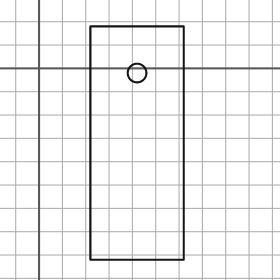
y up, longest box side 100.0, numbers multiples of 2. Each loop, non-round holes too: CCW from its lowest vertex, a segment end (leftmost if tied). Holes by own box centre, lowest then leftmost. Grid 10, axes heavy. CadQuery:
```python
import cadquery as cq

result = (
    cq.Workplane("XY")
    .moveTo(22.0, -82.0)
    .lineTo(62.0, -82.0)
    .lineTo(62.0, 18.0)
    .lineTo(22.0, 18.0)
    .close()
    .moveTo(42.0, -2.0)
    .circle(4.0)
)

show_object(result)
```